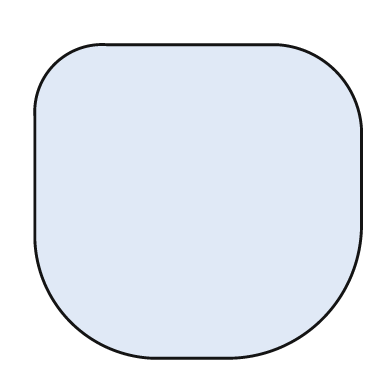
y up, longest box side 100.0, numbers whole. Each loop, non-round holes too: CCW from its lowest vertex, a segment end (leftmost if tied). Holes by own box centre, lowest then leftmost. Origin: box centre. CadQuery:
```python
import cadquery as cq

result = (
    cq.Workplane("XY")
    .moveTo(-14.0, -48.0)
    .lineTo(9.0, -48.0)
    .threePointArc((38.0, -36.0), (50.0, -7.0))
    .lineTo(50.0, 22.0)
    .threePointArc((42.0, 40.0), (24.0, 48.0))
    .lineTo(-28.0, 48.0)
    .threePointArc((-44.0, 42.0), (-50.0, 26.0))
    .lineTo(-50.0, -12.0)
    .threePointArc((-39.0, -37.0), (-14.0, -48.0))
    .close()
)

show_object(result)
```